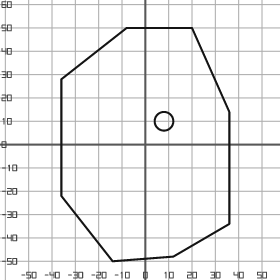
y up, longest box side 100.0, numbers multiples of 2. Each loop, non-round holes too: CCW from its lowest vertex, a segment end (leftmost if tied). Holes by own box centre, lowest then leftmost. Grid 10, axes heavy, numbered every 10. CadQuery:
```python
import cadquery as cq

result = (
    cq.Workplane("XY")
    .moveTo(-14.0, -50.0)
    .lineTo(12.0, -48.0)
    .lineTo(36.0, -34.0)
    .lineTo(36.0, 14.0)
    .lineTo(20.0, 50.0)
    .lineTo(-8.0, 50.0)
    .lineTo(-36.0, 28.0)
    .lineTo(-36.0, -22.0)
    .close()
    .moveTo(8.0, 10.0)
    .circle(4.0)
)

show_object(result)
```